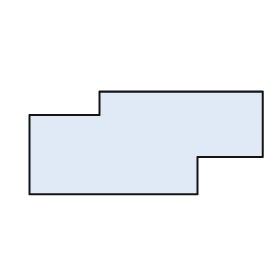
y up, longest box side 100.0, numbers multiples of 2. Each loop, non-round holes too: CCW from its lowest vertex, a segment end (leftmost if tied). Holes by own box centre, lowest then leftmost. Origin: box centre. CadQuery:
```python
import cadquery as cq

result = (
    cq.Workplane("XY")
    .moveTo(-50.0, -22.0)
    .lineTo(22.0, -22.0)
    .lineTo(22.0, -6.0)
    .lineTo(50.0, -6.0)
    .lineTo(50.0, 22.0)
    .lineTo(-20.0, 22.0)
    .lineTo(-20.0, 12.0)
    .lineTo(-50.0, 12.0)
    .close()
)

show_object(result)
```